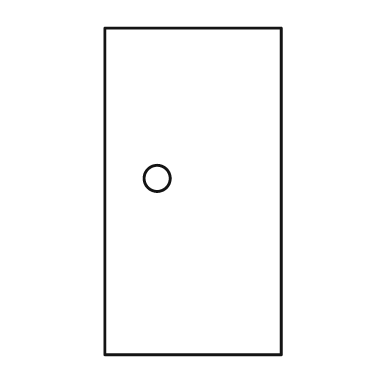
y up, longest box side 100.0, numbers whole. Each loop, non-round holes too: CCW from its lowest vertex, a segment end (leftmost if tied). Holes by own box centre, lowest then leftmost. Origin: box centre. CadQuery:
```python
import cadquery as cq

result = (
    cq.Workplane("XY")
    .moveTo(-27.0, -50.0)
    .lineTo(27.0, -50.0)
    .lineTo(27.0, 50.0)
    .lineTo(-27.0, 50.0)
    .close()
    .moveTo(-11.0, 4.0)
    .circle(4.0)
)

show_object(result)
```